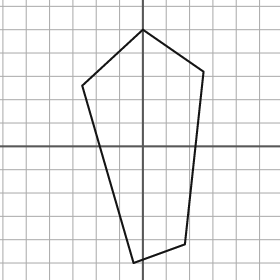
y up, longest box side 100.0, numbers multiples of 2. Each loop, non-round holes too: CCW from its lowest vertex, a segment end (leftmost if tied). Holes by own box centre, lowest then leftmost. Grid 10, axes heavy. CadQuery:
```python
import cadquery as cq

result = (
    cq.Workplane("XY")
    .moveTo(-4.0, -50.0)
    .lineTo(18.0, -42.0)
    .lineTo(26.0, 32.0)
    .lineTo(0.0, 50.0)
    .lineTo(-26.0, 26.0)
    .close()
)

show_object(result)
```